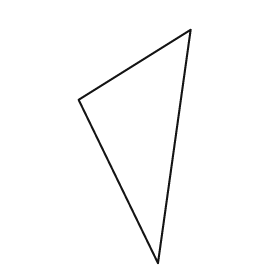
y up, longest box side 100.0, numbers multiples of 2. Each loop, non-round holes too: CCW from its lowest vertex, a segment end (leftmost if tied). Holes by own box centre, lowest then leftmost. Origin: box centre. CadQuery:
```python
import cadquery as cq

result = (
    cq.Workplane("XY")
    .moveTo(10.0, -50.0)
    .lineTo(24.0, 50.0)
    .lineTo(-24.0, 20.0)
    .close()
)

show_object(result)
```